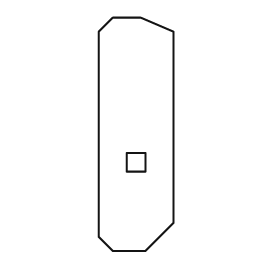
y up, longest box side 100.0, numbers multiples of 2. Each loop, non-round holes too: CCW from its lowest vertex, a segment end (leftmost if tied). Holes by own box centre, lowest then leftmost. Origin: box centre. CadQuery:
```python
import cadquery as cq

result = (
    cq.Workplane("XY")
    .moveTo(-10.0, -50.0)
    .lineTo(4.0, -50.0)
    .lineTo(16.0, -38.0)
    .lineTo(16.0, 44.0)
    .lineTo(2.0, 50.0)
    .lineTo(-10.0, 50.0)
    .lineTo(-16.0, 44.0)
    .lineTo(-16.0, -44.0)
    .close()
    .moveTo(-4.0, -16.0)
    .lineTo(4.0, -16.0)
    .lineTo(4.0, -8.0)
    .lineTo(-4.0, -8.0)
    .close()
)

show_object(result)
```